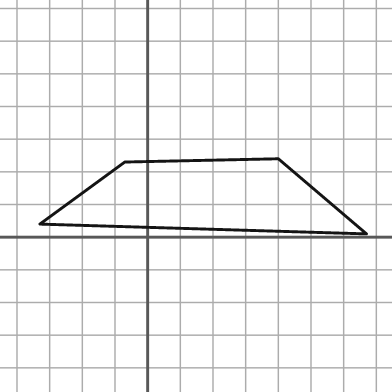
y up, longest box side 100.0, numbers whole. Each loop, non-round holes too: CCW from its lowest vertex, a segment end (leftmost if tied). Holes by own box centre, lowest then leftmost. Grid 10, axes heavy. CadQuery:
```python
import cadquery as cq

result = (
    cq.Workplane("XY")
    .moveTo(67.0, 1.0)
    .lineTo(40.0, 24.0)
    .lineTo(-7.0, 23.0)
    .lineTo(-33.0, 4.0)
    .close()
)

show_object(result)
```